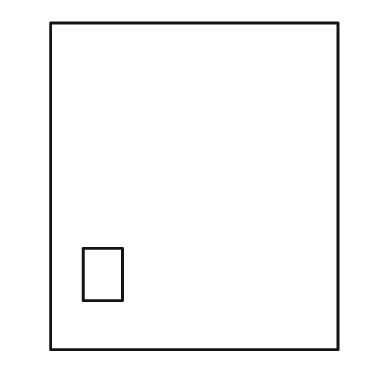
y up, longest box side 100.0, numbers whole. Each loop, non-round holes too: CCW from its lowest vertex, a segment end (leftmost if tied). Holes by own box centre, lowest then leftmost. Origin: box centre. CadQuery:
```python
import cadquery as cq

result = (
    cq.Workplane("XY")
    .moveTo(-44.0, -50.0)
    .lineTo(44.0, -50.0)
    .lineTo(44.0, 50.0)
    .lineTo(-44.0, 50.0)
    .close()
    .moveTo(-34.0, -35.0)
    .lineTo(-22.0, -35.0)
    .lineTo(-22.0, -19.0)
    .lineTo(-34.0, -19.0)
    .close()
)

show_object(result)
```